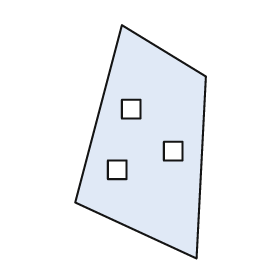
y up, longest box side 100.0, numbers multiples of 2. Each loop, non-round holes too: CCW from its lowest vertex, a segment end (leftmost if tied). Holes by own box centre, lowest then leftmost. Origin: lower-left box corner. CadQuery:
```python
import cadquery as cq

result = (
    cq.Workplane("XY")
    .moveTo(52.0, 0.0)
    .lineTo(56.0, 78.0)
    .lineTo(20.0, 100.0)
    .lineTo(0.0, 24.0)
    .close()
    .moveTo(14.0, 34.0)
    .lineTo(22.0, 34.0)
    .lineTo(22.0, 42.0)
    .lineTo(14.0, 42.0)
    .close()
    .moveTo(38.0, 42.0)
    .lineTo(46.0, 42.0)
    .lineTo(46.0, 50.0)
    .lineTo(38.0, 50.0)
    .close()
    .moveTo(20.0, 60.0)
    .lineTo(28.0, 60.0)
    .lineTo(28.0, 68.0)
    .lineTo(20.0, 68.0)
    .close()
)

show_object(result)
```